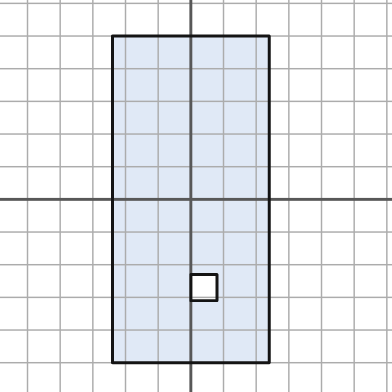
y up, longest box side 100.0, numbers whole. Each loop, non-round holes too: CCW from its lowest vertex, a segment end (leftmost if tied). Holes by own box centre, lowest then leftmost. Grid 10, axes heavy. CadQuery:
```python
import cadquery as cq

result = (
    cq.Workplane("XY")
    .moveTo(-24.0, -50.0)
    .lineTo(24.0, -50.0)
    .lineTo(24.0, 50.0)
    .lineTo(-24.0, 50.0)
    .close()
    .moveTo(0.0, -31.0)
    .lineTo(8.0, -31.0)
    .lineTo(8.0, -23.0)
    .lineTo(0.0, -23.0)
    .close()
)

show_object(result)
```